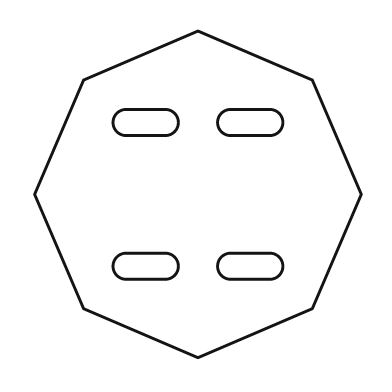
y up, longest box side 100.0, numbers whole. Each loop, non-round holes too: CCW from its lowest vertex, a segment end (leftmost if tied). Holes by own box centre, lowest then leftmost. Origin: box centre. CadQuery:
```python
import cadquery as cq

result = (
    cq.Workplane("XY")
    .moveTo(0.0, -50.0)
    .lineTo(35.0, -35.0)
    .lineTo(50.0, 0.0)
    .lineTo(35.0, 35.0)
    .lineTo(0.0, 50.0)
    .lineTo(-35.0, 35.0)
    .lineTo(-50.0, 0.0)
    .lineTo(-35.0, -35.0)
    .close()
    .moveTo(-22.0, -26.0)
    .lineTo(-10.0, -26.0)
    .threePointArc((-6.0, -22.0), (-10.0, -18.0))
    .lineTo(-22.0, -18.0)
    .threePointArc((-26.0, -22.0), (-22.0, -26.0))
    .close()
    .moveTo(10.0, -26.0)
    .lineTo(22.0, -26.0)
    .threePointArc((26.0, -22.0), (22.0, -18.0))
    .lineTo(10.0, -18.0)
    .threePointArc((6.0, -22.0), (10.0, -26.0))
    .close()
    .moveTo(-22.0, 18.0)
    .lineTo(-10.0, 18.0)
    .threePointArc((-6.0, 22.0), (-10.0, 26.0))
    .lineTo(-22.0, 26.0)
    .threePointArc((-26.0, 22.0), (-22.0, 18.0))
    .close()
    .moveTo(10.0, 18.0)
    .lineTo(22.0, 18.0)
    .threePointArc((26.0, 22.0), (22.0, 26.0))
    .lineTo(10.0, 26.0)
    .threePointArc((6.0, 22.0), (10.0, 18.0))
    .close()
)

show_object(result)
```